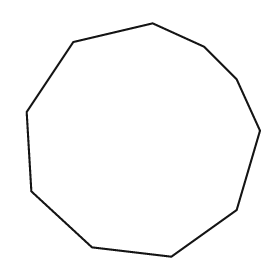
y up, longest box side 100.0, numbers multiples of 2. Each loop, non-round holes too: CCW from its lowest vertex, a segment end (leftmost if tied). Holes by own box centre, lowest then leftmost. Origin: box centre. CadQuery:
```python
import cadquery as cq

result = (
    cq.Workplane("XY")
    .moveTo(12.0, -50.0)
    .lineTo(40.0, -30.0)
    .lineTo(50.0, 4.0)
    .lineTo(40.0, 26.0)
    .lineTo(26.0, 40.0)
    .lineTo(4.0, 50.0)
    .lineTo(-30.0, 42.0)
    .lineTo(-50.0, 12.0)
    .lineTo(-48.0, -22.0)
    .lineTo(-22.0, -46.0)
    .close()
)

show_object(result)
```